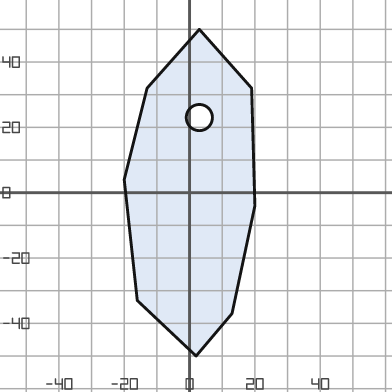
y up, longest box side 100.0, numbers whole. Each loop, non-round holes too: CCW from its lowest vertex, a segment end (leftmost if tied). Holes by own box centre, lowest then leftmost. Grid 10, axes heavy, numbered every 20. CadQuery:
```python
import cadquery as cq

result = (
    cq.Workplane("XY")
    .moveTo(2.0, -50.0)
    .lineTo(13.0, -37.0)
    .lineTo(20.0, -4.0)
    .lineTo(19.0, 32.0)
    .lineTo(3.0, 50.0)
    .lineTo(-13.0, 32.0)
    .lineTo(-20.0, 4.0)
    .lineTo(-16.0, -33.0)
    .close()
    .moveTo(3.0, 23.0)
    .circle(4.0)
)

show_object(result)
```